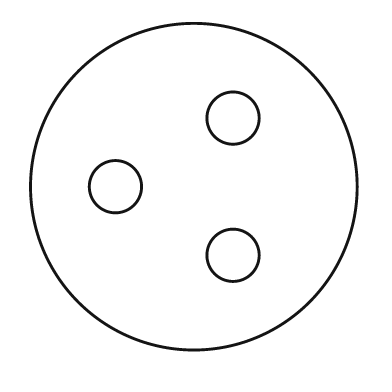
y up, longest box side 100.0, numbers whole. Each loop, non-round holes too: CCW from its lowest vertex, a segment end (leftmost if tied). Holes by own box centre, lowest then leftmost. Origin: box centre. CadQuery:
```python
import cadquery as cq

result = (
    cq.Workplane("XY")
    .moveTo(0.0, 0.0)
    .circle(50.0)
    .moveTo(12.0, -21.0)
    .circle(8.0)
    .moveTo(-24.0, 0.0)
    .circle(8.0)
    .moveTo(12.0, 21.0)
    .circle(8.0)
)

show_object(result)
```